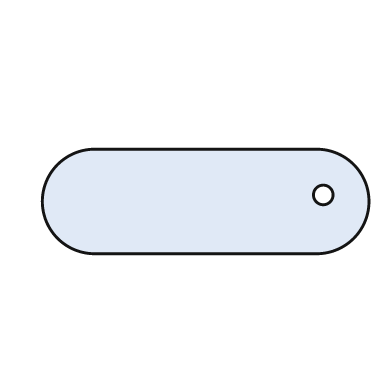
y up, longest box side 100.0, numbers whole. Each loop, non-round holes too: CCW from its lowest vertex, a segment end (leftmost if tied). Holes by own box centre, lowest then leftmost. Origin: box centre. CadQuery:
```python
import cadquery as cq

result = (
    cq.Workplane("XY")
    .moveTo(-34.0, -16.0)
    .lineTo(34.0, -16.0)
    .threePointArc((50.0, 0.0), (34.0, 16.0))
    .lineTo(-34.0, 16.0)
    .threePointArc((-50.0, 0.0), (-34.0, -16.0))
    .close()
    .moveTo(36.0, 2.0)
    .circle(3.0)
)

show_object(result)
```